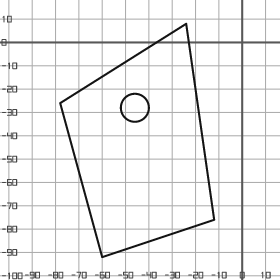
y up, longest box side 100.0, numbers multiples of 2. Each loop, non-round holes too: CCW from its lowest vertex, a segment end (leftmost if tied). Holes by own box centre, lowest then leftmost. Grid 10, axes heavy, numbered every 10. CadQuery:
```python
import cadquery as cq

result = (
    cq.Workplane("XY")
    .moveTo(-60.0, -92.0)
    .lineTo(-12.0, -76.0)
    .lineTo(-24.0, 8.0)
    .lineTo(-78.0, -26.0)
    .close()
    .moveTo(-46.0, -28.0)
    .circle(6.0)
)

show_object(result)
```